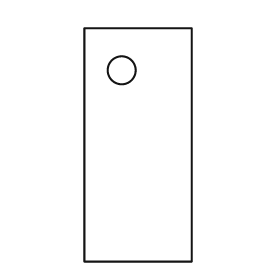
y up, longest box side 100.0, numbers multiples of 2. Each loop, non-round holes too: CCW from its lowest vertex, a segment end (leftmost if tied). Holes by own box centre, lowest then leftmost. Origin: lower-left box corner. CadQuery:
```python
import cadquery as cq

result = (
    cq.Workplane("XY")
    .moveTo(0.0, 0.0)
    .lineTo(46.0, 0.0)
    .lineTo(46.0, 100.0)
    .lineTo(0.0, 100.0)
    .close()
    .moveTo(16.0, 82.0)
    .circle(6.0)
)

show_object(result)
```